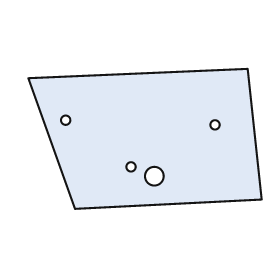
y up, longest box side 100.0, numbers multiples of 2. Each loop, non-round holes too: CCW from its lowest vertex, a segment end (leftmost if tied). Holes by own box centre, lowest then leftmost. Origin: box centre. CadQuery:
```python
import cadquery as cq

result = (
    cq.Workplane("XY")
    .moveTo(-30.0, -30.0)
    .lineTo(50.0, -26.0)
    .lineTo(44.0, 30.0)
    .lineTo(-50.0, 26.0)
    .close()
    .moveTo(4.0, -16.0)
    .circle(4.0)
    .moveTo(-6.0, -12.0)
    .circle(2.0)
    .moveTo(30.0, 6.0)
    .circle(2.0)
    .moveTo(-34.0, 8.0)
    .circle(2.0)
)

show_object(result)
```